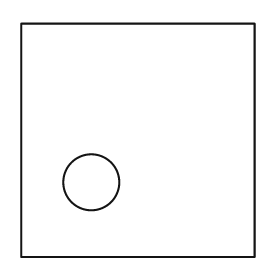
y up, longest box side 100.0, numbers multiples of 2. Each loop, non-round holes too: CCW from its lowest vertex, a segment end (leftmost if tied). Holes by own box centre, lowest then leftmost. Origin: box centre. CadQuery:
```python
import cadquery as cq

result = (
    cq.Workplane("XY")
    .moveTo(-50.0, -50.0)
    .lineTo(50.0, -50.0)
    .lineTo(50.0, 50.0)
    .lineTo(-50.0, 50.0)
    .close()
    .moveTo(-20.0, -18.0)
    .circle(12.0)
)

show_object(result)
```